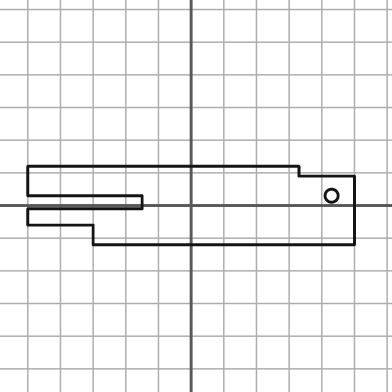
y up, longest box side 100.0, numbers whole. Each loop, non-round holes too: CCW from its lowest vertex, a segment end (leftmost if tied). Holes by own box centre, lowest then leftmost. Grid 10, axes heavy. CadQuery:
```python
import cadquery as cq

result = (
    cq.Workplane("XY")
    .moveTo(-30.0, -12.0)
    .lineTo(50.0, -12.0)
    .lineTo(50.0, 9.0)
    .lineTo(33.0, 9.0)
    .lineTo(33.0, 12.0)
    .lineTo(-50.0, 12.0)
    .lineTo(-50.0, 3.0)
    .lineTo(-15.0, 3.0)
    .lineTo(-15.0, -1.0)
    .lineTo(-50.0, -1.0)
    .lineTo(-50.0, -6.0)
    .lineTo(-30.0, -6.0)
    .close()
    .moveTo(43.0, 3.0)
    .circle(2.0)
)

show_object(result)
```